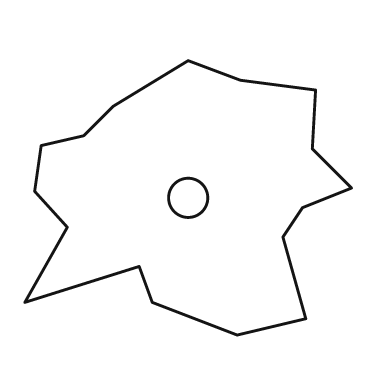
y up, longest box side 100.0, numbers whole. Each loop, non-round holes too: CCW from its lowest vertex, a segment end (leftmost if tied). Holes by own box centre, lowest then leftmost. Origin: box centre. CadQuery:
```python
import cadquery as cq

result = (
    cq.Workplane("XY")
    .moveTo(15.0, -42.0)
    .lineTo(36.0, -37.0)
    .lineTo(29.0, -12.0)
    .lineTo(35.0, -3.0)
    .lineTo(50.0, 3.0)
    .lineTo(38.0, 15.0)
    .lineTo(39.0, 33.0)
    .lineTo(16.0, 36.0)
    .lineTo(0.0, 42.0)
    .lineTo(-23.0, 28.0)
    .lineTo(-32.0, 19.0)
    .lineTo(-45.0, 16.0)
    .lineTo(-47.0, 2.0)
    .lineTo(-37.0, -9.0)
    .lineTo(-50.0, -32.0)
    .lineTo(-15.0, -21.0)
    .lineTo(-11.0, -32.0)
    .close()
    .moveTo(0.0, 0.0)
    .circle(6.0)
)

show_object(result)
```